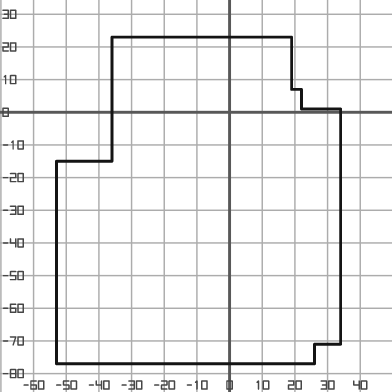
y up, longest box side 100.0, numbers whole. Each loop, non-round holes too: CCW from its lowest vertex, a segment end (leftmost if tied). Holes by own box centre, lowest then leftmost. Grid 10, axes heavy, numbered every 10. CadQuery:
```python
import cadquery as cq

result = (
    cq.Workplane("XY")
    .moveTo(-53.0, -77.0)
    .lineTo(26.0, -77.0)
    .lineTo(26.0, -71.0)
    .lineTo(34.0, -71.0)
    .lineTo(34.0, 1.0)
    .lineTo(22.0, 1.0)
    .lineTo(22.0, 7.0)
    .lineTo(19.0, 7.0)
    .lineTo(19.0, 23.0)
    .lineTo(-36.0, 23.0)
    .lineTo(-36.0, -15.0)
    .lineTo(-53.0, -15.0)
    .close()
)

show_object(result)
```